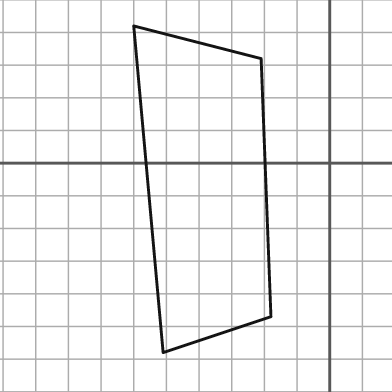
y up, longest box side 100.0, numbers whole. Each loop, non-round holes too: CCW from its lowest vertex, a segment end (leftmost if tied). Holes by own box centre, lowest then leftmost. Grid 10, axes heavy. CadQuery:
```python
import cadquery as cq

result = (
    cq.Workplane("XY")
    .moveTo(-51.0, -58.0)
    .lineTo(-18.0, -47.0)
    .lineTo(-21.0, 32.0)
    .lineTo(-60.0, 42.0)
    .close()
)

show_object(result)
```